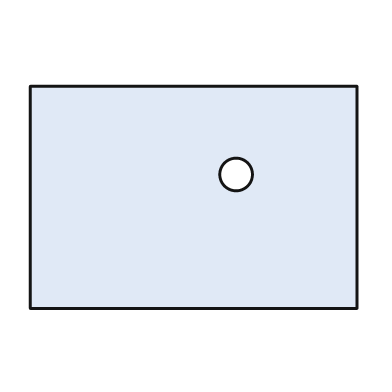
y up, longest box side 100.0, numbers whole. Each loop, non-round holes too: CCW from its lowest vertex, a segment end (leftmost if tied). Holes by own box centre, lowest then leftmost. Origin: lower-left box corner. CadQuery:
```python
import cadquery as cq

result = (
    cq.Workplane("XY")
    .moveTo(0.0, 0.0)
    .lineTo(100.0, 0.0)
    .lineTo(100.0, 68.0)
    .lineTo(0.0, 68.0)
    .close()
    .moveTo(63.0, 41.0)
    .circle(5.0)
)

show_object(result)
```